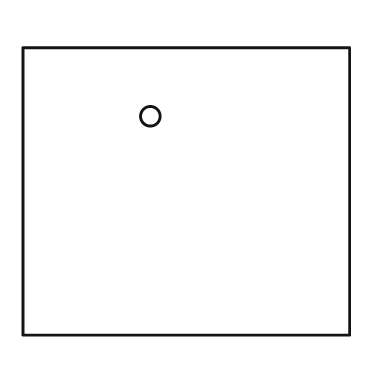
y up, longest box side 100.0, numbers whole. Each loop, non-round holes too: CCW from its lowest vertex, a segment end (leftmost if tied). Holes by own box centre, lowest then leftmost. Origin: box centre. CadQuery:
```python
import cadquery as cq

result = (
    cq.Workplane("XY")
    .moveTo(-50.0, -44.0)
    .lineTo(50.0, -44.0)
    .lineTo(50.0, 44.0)
    .lineTo(-50.0, 44.0)
    .close()
    .moveTo(-11.0, 23.0)
    .circle(3.0)
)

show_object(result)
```